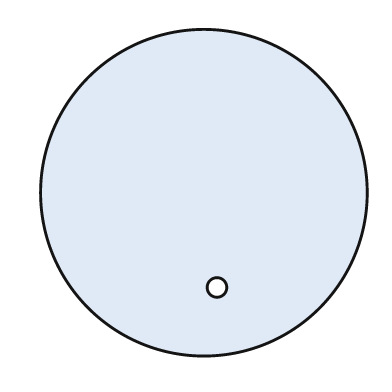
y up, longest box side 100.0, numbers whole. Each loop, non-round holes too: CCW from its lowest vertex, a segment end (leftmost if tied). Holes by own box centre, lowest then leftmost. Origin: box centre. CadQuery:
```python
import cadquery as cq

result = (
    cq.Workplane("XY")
    .moveTo(0.0, 0.0)
    .circle(50.0)
    .moveTo(4.0, -29.0)
    .circle(3.0)
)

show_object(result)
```